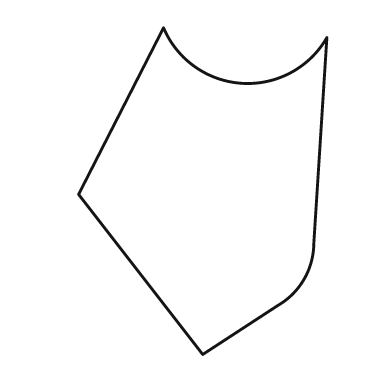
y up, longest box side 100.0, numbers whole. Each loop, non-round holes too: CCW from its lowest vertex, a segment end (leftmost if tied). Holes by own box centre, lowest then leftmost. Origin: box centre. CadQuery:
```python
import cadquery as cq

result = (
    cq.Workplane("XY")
    .moveTo(0.0, -50.0)
    .lineTo(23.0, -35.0)
    .threePointArc((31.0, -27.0), (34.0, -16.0))
    .lineTo(38.0, 47.0)
    .threePointArc((12.0, 33.0), (-12.0, 50.0))
    .lineTo(-38.0, -1.0)
    .close()
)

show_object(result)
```